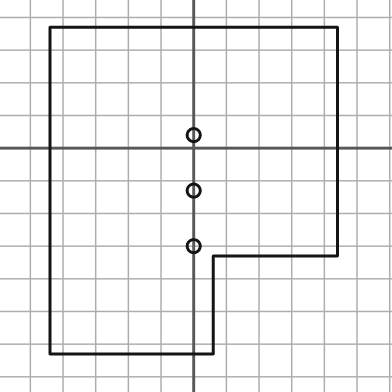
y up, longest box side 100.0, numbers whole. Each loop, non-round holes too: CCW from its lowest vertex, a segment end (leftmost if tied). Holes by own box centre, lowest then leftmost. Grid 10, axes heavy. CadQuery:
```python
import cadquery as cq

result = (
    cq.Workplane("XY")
    .moveTo(-44.0, -63.0)
    .lineTo(6.0, -63.0)
    .lineTo(6.0, -33.0)
    .lineTo(44.0, -33.0)
    .lineTo(44.0, 37.0)
    .lineTo(-44.0, 37.0)
    .close()
    .moveTo(0.0, -30.0)
    .circle(2.0)
    .moveTo(0.0, -13.0)
    .circle(2.0)
    .moveTo(0.0, 4.0)
    .circle(2.0)
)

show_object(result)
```